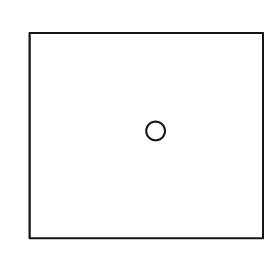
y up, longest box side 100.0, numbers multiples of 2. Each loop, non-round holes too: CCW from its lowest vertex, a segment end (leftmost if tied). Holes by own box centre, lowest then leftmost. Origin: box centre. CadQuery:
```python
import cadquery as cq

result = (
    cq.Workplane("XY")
    .moveTo(-50.0, -44.0)
    .lineTo(50.0, -44.0)
    .lineTo(50.0, 44.0)
    .lineTo(-50.0, 44.0)
    .close()
    .moveTo(4.0, 2.0)
    .circle(4.0)
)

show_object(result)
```